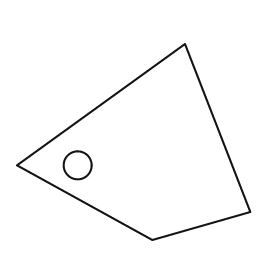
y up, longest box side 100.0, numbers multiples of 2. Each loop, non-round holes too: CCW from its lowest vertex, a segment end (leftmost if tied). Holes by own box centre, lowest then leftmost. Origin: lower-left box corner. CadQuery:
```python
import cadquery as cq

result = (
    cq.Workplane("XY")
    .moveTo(58.0, 0.0)
    .lineTo(100.0, 12.0)
    .lineTo(72.0, 84.0)
    .lineTo(0.0, 32.0)
    .close()
    .moveTo(26.0, 32.0)
    .circle(6.0)
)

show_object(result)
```